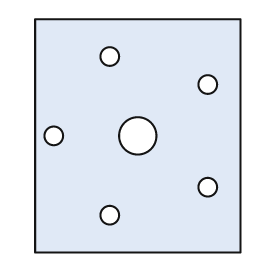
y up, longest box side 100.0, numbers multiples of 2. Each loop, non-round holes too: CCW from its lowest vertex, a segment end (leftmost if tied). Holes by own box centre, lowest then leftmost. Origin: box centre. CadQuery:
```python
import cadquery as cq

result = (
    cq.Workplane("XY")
    .moveTo(-44.0, -50.0)
    .lineTo(44.0, -50.0)
    .lineTo(44.0, 50.0)
    .lineTo(-44.0, 50.0)
    .close()
    .moveTo(-12.0, -34.0)
    .circle(4.0)
    .moveTo(30.0, -22.0)
    .circle(4.0)
    .moveTo(-36.0, 0.0)
    .circle(4.0)
    .moveTo(0.0, 0.0)
    .circle(8.0)
    .moveTo(30.0, 22.0)
    .circle(4.0)
    .moveTo(-12.0, 34.0)
    .circle(4.0)
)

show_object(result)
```